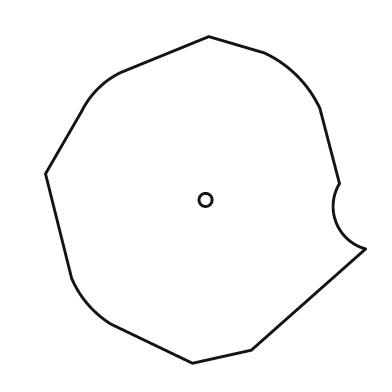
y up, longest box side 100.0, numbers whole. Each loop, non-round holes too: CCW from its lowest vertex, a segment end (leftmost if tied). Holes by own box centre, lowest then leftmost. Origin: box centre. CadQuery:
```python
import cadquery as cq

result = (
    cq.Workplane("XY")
    .moveTo(-4.0, -50.0)
    .lineTo(14.0, -46.0)
    .lineTo(49.0, -15.0)
    .threePointArc((40.0, -7.0), (41.0, 5.0))
    .lineTo(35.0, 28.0)
    .threePointArc((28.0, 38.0), (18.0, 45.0))
    .lineTo(1.0, 50.0)
    .lineTo(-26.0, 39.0)
    .threePointArc((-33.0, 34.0), (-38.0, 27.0))
    .lineTo(-49.0, 8.0)
    .lineTo(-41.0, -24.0)
    .threePointArc((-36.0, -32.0), (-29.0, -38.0))
    .close()
    .moveTo(0.0, 0.0)
    .circle(2.0)
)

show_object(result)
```